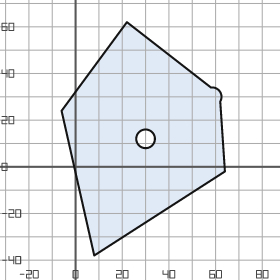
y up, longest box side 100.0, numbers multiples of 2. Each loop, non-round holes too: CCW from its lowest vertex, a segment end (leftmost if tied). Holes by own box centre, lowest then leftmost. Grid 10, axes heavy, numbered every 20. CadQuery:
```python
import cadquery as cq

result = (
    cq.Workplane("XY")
    .moveTo(8.0, -38.0)
    .lineTo(64.0, -2.0)
    .lineTo(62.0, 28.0)
    .threePointArc((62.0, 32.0), (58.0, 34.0))
    .lineTo(22.0, 62.0)
    .lineTo(-6.0, 24.0)
    .close()
    .moveTo(30.0, 12.0)
    .circle(4.0)
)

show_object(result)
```